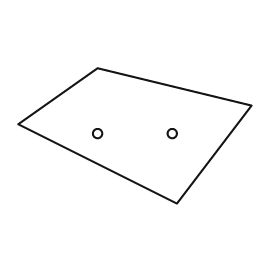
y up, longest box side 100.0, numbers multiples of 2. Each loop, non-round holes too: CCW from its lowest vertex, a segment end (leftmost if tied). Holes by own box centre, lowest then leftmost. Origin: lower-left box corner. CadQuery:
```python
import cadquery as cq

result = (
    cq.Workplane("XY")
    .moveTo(68.0, 0.0)
    .lineTo(100.0, 42.0)
    .lineTo(34.0, 58.0)
    .lineTo(0.0, 34.0)
    .close()
    .moveTo(34.0, 30.0)
    .circle(2.0)
    .moveTo(66.0, 30.0)
    .circle(2.0)
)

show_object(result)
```